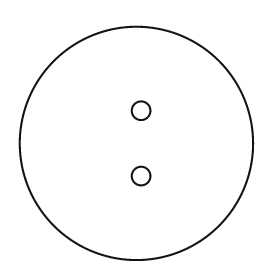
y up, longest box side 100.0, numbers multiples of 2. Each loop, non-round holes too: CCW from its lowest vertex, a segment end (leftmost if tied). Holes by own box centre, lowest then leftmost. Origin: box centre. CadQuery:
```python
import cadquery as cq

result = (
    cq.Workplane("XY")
    .moveTo(0.0, 0.0)
    .circle(50.0)
    .moveTo(2.0, -14.0)
    .circle(4.0)
    .moveTo(2.0, 14.0)
    .circle(4.0)
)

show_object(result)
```